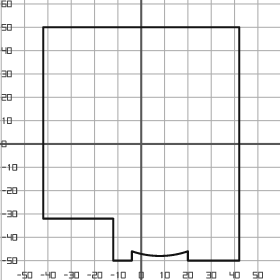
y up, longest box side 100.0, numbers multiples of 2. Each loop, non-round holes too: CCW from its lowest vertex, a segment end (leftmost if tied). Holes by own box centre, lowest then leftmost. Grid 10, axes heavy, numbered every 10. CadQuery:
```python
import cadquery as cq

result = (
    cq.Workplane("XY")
    .moveTo(-12.0, -50.0)
    .lineTo(-4.0, -50.0)
    .lineTo(-4.0, -46.0)
    .threePointArc((8.0, -48.0), (20.0, -46.0))
    .lineTo(20.0, -50.0)
    .lineTo(42.0, -50.0)
    .lineTo(42.0, 50.0)
    .lineTo(-42.0, 50.0)
    .lineTo(-42.0, -32.0)
    .lineTo(-12.0, -32.0)
    .close()
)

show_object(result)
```